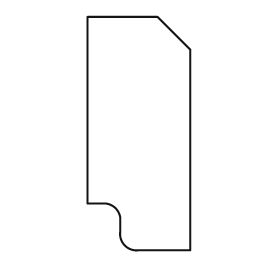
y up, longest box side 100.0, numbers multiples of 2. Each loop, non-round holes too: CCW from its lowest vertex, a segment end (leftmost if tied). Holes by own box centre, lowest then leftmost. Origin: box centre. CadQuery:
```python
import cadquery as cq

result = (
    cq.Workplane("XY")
    .moveTo(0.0, -50.0)
    .lineTo(22.0, -50.0)
    .lineTo(22.0, 36.0)
    .lineTo(8.0, 50.0)
    .lineTo(-22.0, 50.0)
    .lineTo(-22.0, -30.0)
    .lineTo(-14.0, -30.0)
    .threePointArc((-10.0, -32.0), (-8.0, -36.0))
    .lineTo(-8.0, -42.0)
    .threePointArc((-6.0, -48.0), (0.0, -50.0))
    .close()
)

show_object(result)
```